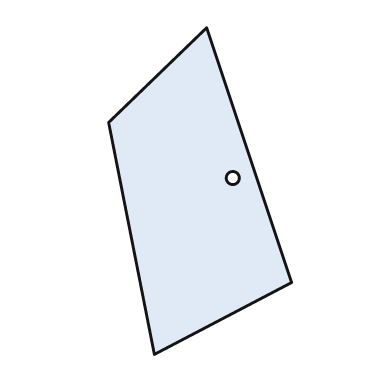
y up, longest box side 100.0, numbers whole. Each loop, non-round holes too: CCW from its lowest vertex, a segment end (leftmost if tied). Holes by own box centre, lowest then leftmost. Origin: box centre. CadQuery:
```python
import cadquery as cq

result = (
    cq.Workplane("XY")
    .moveTo(-14.0, -50.0)
    .lineTo(28.0, -28.0)
    .lineTo(2.0, 50.0)
    .lineTo(-28.0, 21.0)
    .close()
    .moveTo(10.0, 4.0)
    .circle(2.0)
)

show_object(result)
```